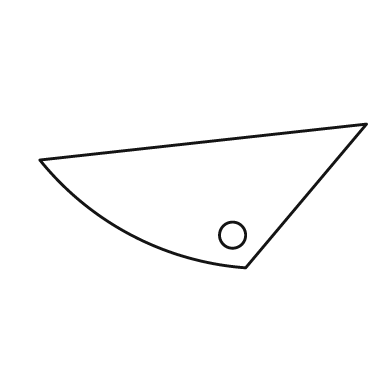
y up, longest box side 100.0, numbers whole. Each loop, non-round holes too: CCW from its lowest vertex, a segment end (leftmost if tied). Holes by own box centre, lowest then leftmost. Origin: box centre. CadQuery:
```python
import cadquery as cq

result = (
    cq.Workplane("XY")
    .moveTo(13.0, -22.0)
    .lineTo(50.0, 22.0)
    .lineTo(-50.0, 11.0)
    .threePointArc((-22.0, -12.0), (13.0, -22.0))
    .close()
    .moveTo(9.0, -12.0)
    .circle(4.0)
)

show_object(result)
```